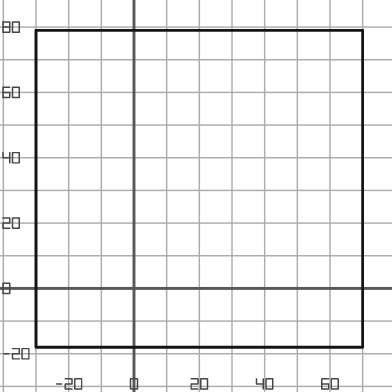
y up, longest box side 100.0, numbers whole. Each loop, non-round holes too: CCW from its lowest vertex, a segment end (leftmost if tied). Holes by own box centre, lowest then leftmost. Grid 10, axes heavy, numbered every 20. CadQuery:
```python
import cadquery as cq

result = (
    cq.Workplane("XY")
    .moveTo(-30.0, -18.0)
    .lineTo(70.0, -18.0)
    .lineTo(70.0, 79.0)
    .lineTo(-30.0, 79.0)
    .close()
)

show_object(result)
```